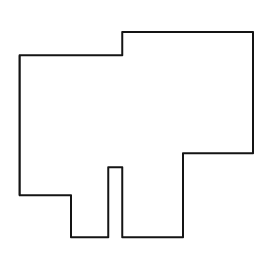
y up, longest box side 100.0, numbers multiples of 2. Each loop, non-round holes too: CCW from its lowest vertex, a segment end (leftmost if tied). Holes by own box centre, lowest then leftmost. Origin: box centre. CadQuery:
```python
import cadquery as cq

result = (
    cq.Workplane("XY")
    .moveTo(-28.0, -44.0)
    .lineTo(-12.0, -44.0)
    .lineTo(-12.0, -14.0)
    .lineTo(-6.0, -14.0)
    .lineTo(-6.0, -44.0)
    .lineTo(20.0, -44.0)
    .lineTo(20.0, -8.0)
    .lineTo(50.0, -8.0)
    .lineTo(50.0, 44.0)
    .lineTo(-6.0, 44.0)
    .lineTo(-6.0, 34.0)
    .lineTo(-50.0, 34.0)
    .lineTo(-50.0, -26.0)
    .lineTo(-28.0, -26.0)
    .close()
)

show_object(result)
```